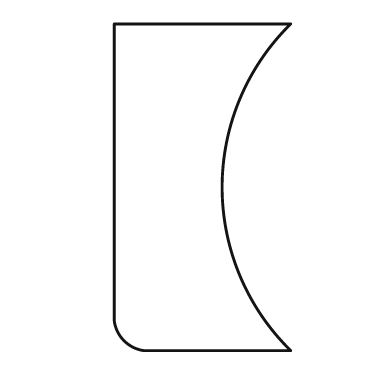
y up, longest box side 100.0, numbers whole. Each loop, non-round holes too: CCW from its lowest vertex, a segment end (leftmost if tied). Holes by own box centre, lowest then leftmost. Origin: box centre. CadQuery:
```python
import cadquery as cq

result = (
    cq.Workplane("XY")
    .moveTo(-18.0, -50.0)
    .lineTo(27.0, -50.0)
    .threePointArc((6.0, 0.0), (27.0, 50.0))
    .lineTo(-27.0, 50.0)
    .lineTo(-27.0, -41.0)
    .threePointArc((-24.0, -47.0), (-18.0, -50.0))
    .close()
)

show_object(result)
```